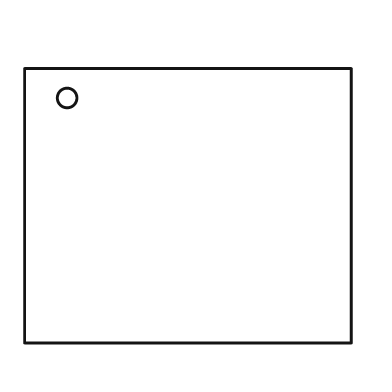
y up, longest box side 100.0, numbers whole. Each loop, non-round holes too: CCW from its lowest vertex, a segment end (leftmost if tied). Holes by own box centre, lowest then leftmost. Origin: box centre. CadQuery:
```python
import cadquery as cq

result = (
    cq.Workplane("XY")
    .moveTo(-50.0, -42.0)
    .lineTo(50.0, -42.0)
    .lineTo(50.0, 42.0)
    .lineTo(-50.0, 42.0)
    .close()
    .moveTo(-37.0, 33.0)
    .circle(3.0)
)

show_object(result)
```